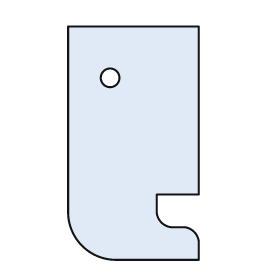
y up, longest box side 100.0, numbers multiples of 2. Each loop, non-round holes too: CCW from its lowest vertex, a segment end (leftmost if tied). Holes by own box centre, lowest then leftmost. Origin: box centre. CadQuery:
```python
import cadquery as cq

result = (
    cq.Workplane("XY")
    .moveTo(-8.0, -50.0)
    .lineTo(28.0, -50.0)
    .lineTo(28.0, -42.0)
    .threePointArc((26.0, -38.0), (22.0, -36.0))
    .lineTo(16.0, -36.0)
    .threePointArc((12.0, -34.0), (10.0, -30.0))
    .lineTo(10.0, -22.0)
    .lineTo(28.0, -22.0)
    .lineTo(28.0, 50.0)
    .lineTo(-28.0, 50.0)
    .lineTo(-28.0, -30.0)
    .threePointArc((-22.0, -44.0), (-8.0, -50.0))
    .close()
    .moveTo(-10.0, 28.0)
    .circle(4.0)
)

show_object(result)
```